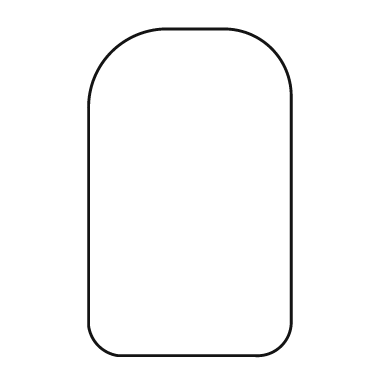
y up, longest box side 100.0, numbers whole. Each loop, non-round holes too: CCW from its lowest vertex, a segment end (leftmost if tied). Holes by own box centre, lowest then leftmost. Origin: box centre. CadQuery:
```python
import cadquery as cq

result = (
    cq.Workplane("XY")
    .moveTo(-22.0, -50.0)
    .lineTo(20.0, -50.0)
    .threePointArc((28.0, -47.0), (31.0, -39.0))
    .lineTo(31.0, 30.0)
    .threePointArc((25.0, 44.0), (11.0, 50.0))
    .lineTo(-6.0, 50.0)
    .threePointArc((-24.0, 43.0), (-31.0, 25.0))
    .lineTo(-31.0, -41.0)
    .threePointArc((-28.0, -47.0), (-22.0, -50.0))
    .close()
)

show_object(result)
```